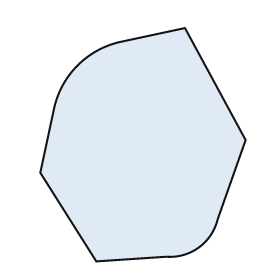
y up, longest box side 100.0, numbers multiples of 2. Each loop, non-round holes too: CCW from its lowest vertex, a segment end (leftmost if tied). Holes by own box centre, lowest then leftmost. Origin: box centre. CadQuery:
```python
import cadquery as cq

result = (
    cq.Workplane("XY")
    .moveTo(-20.0, -50.0)
    .lineTo(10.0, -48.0)
    .threePointArc((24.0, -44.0), (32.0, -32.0))
    .lineTo(44.0, 2.0)
    .lineTo(18.0, 50.0)
    .lineTo(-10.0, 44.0)
    .threePointArc((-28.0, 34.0), (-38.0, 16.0))
    .lineTo(-44.0, -12.0)
    .close()
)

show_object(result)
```